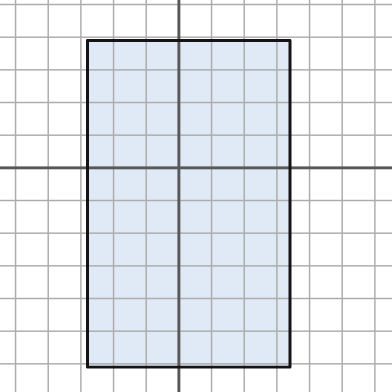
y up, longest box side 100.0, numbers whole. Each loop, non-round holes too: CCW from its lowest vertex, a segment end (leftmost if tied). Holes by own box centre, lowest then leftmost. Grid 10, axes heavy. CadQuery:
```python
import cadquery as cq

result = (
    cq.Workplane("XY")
    .moveTo(-28.0, -61.0)
    .lineTo(34.0, -61.0)
    .lineTo(34.0, 39.0)
    .lineTo(-28.0, 39.0)
    .close()
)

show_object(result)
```